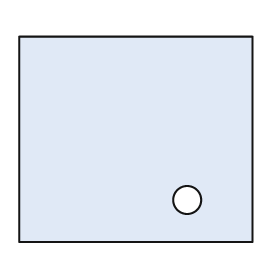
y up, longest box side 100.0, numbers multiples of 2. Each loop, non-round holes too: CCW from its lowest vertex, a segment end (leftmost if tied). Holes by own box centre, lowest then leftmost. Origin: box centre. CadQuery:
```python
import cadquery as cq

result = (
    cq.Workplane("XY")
    .moveTo(-50.0, -44.0)
    .lineTo(50.0, -44.0)
    .lineTo(50.0, 44.0)
    .lineTo(-50.0, 44.0)
    .close()
    .moveTo(22.0, -26.0)
    .circle(6.0)
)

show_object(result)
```